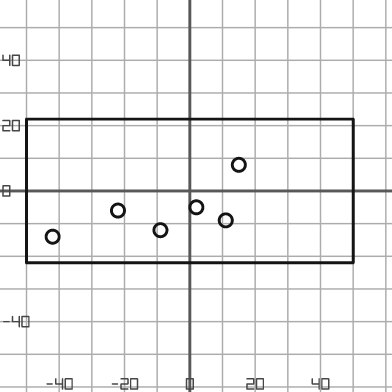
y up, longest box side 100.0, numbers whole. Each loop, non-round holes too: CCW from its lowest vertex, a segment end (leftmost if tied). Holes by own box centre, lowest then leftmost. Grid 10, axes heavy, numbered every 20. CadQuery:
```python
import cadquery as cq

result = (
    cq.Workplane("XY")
    .moveTo(-50.0, -22.0)
    .lineTo(50.0, -22.0)
    .lineTo(50.0, 22.0)
    .lineTo(-50.0, 22.0)
    .close()
    .moveTo(-42.0, -14.0)
    .circle(2.0)
    .moveTo(-9.0, -12.0)
    .circle(2.0)
    .moveTo(11.0, -9.0)
    .circle(2.0)
    .moveTo(-22.0, -6.0)
    .circle(2.0)
    .moveTo(2.0, -5.0)
    .circle(2.0)
    .moveTo(15.0, 8.0)
    .circle(2.0)
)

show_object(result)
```